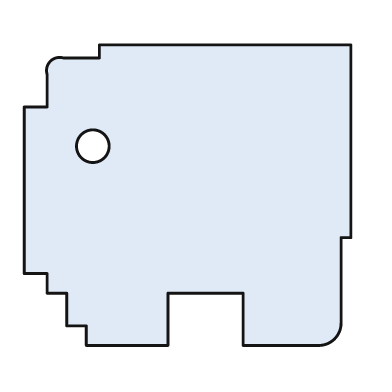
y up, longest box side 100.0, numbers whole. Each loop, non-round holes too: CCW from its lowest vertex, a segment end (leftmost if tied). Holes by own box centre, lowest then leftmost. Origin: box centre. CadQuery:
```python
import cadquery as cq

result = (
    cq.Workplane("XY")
    .moveTo(-31.0, -46.0)
    .lineTo(-6.0, -46.0)
    .lineTo(-6.0, -30.0)
    .lineTo(17.0, -30.0)
    .lineTo(17.0, -46.0)
    .lineTo(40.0, -46.0)
    .threePointArc((45.0, -44.0), (47.0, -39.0))
    .lineTo(47.0, -13.0)
    .lineTo(50.0, -13.0)
    .lineTo(50.0, 46.0)
    .lineTo(-27.0, 46.0)
    .lineTo(-27.0, 42.0)
    .lineTo(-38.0, 42.0)
    .threePointArc((-42.0, 41.0), (-43.0, 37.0))
    .lineTo(-43.0, 27.0)
    .lineTo(-50.0, 27.0)
    .lineTo(-50.0, -24.0)
    .lineTo(-43.0, -24.0)
    .lineTo(-43.0, -30.0)
    .lineTo(-37.0, -30.0)
    .lineTo(-37.0, -40.0)
    .lineTo(-31.0, -40.0)
    .close()
    .moveTo(-29.0, 15.0)
    .circle(5.0)
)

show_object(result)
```